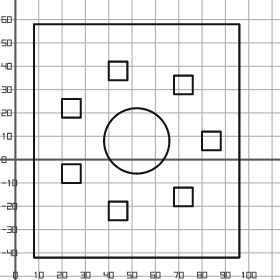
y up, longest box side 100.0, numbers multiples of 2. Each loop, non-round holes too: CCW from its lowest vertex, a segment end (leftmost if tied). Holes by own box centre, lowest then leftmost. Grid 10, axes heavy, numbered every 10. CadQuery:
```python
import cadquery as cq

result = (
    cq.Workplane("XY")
    .moveTo(8.0, -42.0)
    .lineTo(96.0, -42.0)
    .lineTo(96.0, 58.0)
    .lineTo(8.0, 58.0)
    .close()
    .moveTo(40.0, -26.0)
    .lineTo(48.0, -26.0)
    .lineTo(48.0, -18.0)
    .lineTo(40.0, -18.0)
    .close()
    .moveTo(68.0, -20.0)
    .lineTo(76.0, -20.0)
    .lineTo(76.0, -12.0)
    .lineTo(68.0, -12.0)
    .close()
    .moveTo(20.0, -10.0)
    .lineTo(28.0, -10.0)
    .lineTo(28.0, -2.0)
    .lineTo(20.0, -2.0)
    .close()
    .moveTo(52.0, 8.0)
    .circle(14.0)
    .moveTo(80.0, 4.0)
    .lineTo(88.0, 4.0)
    .lineTo(88.0, 12.0)
    .lineTo(80.0, 12.0)
    .close()
    .moveTo(20.0, 18.0)
    .lineTo(28.0, 18.0)
    .lineTo(28.0, 26.0)
    .lineTo(20.0, 26.0)
    .close()
    .moveTo(68.0, 28.0)
    .lineTo(76.0, 28.0)
    .lineTo(76.0, 36.0)
    .lineTo(68.0, 36.0)
    .close()
    .moveTo(40.0, 34.0)
    .lineTo(48.0, 34.0)
    .lineTo(48.0, 42.0)
    .lineTo(40.0, 42.0)
    .close()
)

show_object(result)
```